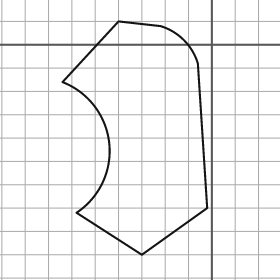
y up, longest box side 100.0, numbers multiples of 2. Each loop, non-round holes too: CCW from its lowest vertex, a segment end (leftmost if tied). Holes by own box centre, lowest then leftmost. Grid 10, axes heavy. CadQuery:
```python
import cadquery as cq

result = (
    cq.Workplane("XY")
    .moveTo(-30.0, -90.0)
    .lineTo(-2.0, -70.0)
    .lineTo(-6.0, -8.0)
    .threePointArc((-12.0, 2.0), (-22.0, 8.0))
    .lineTo(-40.0, 10.0)
    .lineTo(-64.0, -16.0)
    .threePointArc((-44.0, -42.0), (-58.0, -72.0))
    .close()
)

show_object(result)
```